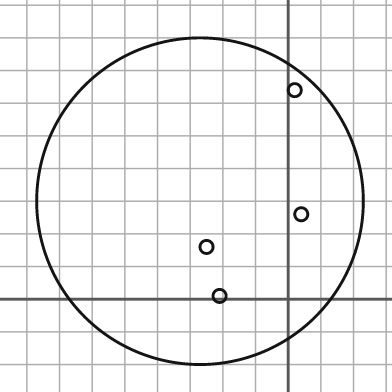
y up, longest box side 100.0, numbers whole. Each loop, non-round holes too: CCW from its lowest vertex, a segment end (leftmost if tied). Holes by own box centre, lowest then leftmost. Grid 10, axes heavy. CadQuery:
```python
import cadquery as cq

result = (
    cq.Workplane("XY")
    .moveTo(-27.0, 30.0)
    .circle(50.0)
    .moveTo(-21.0, 1.0)
    .circle(2.0)
    .moveTo(-25.0, 16.0)
    .circle(2.0)
    .moveTo(4.0, 26.0)
    .circle(2.0)
    .moveTo(2.0, 64.0)
    .circle(2.0)
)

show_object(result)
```